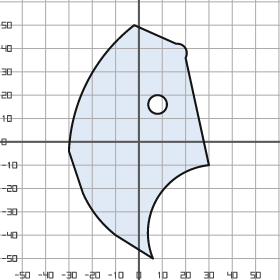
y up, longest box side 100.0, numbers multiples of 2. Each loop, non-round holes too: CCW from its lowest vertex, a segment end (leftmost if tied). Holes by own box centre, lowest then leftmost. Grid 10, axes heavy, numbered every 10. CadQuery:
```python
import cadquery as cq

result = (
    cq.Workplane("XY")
    .moveTo(6.0, -50.0)
    .threePointArc((8.0, -24.0), (30.0, -10.0))
    .lineTo(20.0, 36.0)
    .threePointArc((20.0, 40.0), (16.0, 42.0))
    .lineTo(-2.0, 50.0)
    .threePointArc((-22.0, 26.0), (-30.0, -4.0))
    .lineTo(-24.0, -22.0)
    .threePointArc((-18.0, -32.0), (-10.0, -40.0))
    .close()
    .moveTo(8.0, 16.0)
    .circle(4.0)
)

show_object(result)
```